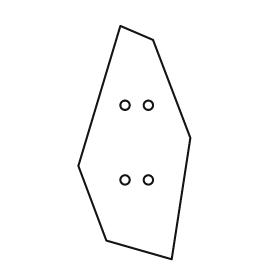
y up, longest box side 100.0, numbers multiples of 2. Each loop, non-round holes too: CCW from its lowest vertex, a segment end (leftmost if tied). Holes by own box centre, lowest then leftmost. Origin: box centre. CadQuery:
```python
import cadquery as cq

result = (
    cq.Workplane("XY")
    .moveTo(16.0, -50.0)
    .lineTo(24.0, 2.0)
    .lineTo(8.0, 44.0)
    .lineTo(-6.0, 50.0)
    .lineTo(-24.0, -10.0)
    .lineTo(-12.0, -42.0)
    .close()
    .moveTo(-4.0, -16.0)
    .circle(2.0)
    .moveTo(6.0, -16.0)
    .circle(2.0)
    .moveTo(-4.0, 16.0)
    .circle(2.0)
    .moveTo(6.0, 16.0)
    .circle(2.0)
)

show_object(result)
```